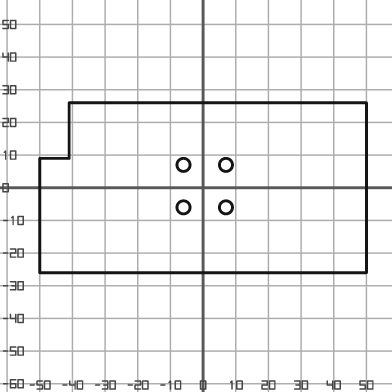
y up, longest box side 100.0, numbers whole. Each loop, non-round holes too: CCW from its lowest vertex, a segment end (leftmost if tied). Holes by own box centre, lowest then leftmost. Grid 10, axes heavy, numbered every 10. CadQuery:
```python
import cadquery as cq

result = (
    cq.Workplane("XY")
    .moveTo(-50.0, -26.0)
    .lineTo(50.0, -26.0)
    .lineTo(50.0, 26.0)
    .lineTo(-41.0, 26.0)
    .lineTo(-41.0, 9.0)
    .lineTo(-50.0, 9.0)
    .close()
    .moveTo(-6.0, -6.0)
    .circle(2.0)
    .moveTo(7.0, -6.0)
    .circle(2.0)
    .moveTo(-6.0, 7.0)
    .circle(2.0)
    .moveTo(7.0, 7.0)
    .circle(2.0)
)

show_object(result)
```